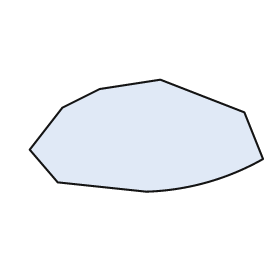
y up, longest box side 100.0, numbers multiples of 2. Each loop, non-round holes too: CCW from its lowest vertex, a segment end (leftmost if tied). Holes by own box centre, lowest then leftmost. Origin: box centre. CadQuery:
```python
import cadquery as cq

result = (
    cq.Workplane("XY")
    .moveTo(0.0, -24.0)
    .threePointArc((26.0, -20.0), (50.0, -10.0))
    .lineTo(42.0, 10.0)
    .lineTo(6.0, 24.0)
    .lineTo(-20.0, 20.0)
    .lineTo(-36.0, 12.0)
    .lineTo(-50.0, -6.0)
    .lineTo(-38.0, -20.0)
    .close()
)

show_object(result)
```